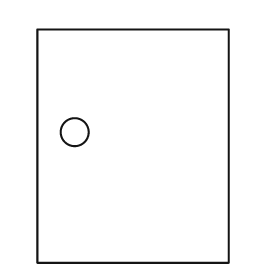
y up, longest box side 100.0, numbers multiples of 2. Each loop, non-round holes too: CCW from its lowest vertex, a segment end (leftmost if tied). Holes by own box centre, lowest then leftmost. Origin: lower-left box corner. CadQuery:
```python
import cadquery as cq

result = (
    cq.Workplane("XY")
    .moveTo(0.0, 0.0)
    .lineTo(82.0, 0.0)
    .lineTo(82.0, 100.0)
    .lineTo(0.0, 100.0)
    .close()
    .moveTo(16.0, 56.0)
    .circle(6.0)
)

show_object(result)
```